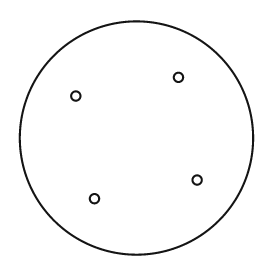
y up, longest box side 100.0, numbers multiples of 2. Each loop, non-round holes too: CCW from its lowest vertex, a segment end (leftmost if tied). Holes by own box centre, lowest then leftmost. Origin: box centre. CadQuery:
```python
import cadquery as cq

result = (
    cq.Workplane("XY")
    .moveTo(0.0, 0.0)
    .circle(50.0)
    .moveTo(-18.0, -26.0)
    .circle(2.0)
    .moveTo(26.0, -18.0)
    .circle(2.0)
    .moveTo(-26.0, 18.0)
    .circle(2.0)
    .moveTo(18.0, 26.0)
    .circle(2.0)
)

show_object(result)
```